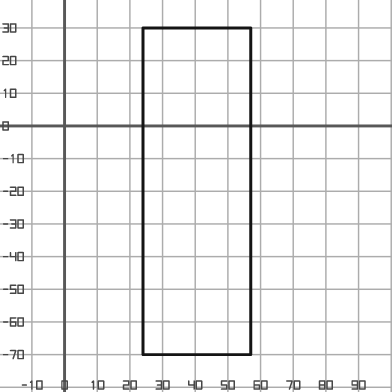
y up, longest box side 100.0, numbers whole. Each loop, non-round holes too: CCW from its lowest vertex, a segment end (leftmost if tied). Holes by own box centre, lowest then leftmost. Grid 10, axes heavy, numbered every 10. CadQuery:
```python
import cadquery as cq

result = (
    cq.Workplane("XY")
    .moveTo(24.0, -70.0)
    .lineTo(57.0, -70.0)
    .lineTo(57.0, 30.0)
    .lineTo(24.0, 30.0)
    .close()
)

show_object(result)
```